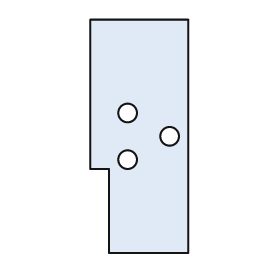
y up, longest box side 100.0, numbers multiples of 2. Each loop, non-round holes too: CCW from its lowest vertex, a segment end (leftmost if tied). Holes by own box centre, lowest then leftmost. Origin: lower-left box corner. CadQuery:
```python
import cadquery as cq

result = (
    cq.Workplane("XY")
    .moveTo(8.0, 0.0)
    .lineTo(42.0, 0.0)
    .lineTo(42.0, 100.0)
    .lineTo(0.0, 100.0)
    .lineTo(0.0, 36.0)
    .lineTo(8.0, 36.0)
    .close()
    .moveTo(16.0, 40.0)
    .circle(4.0)
    .moveTo(34.0, 50.0)
    .circle(4.0)
    .moveTo(16.0, 60.0)
    .circle(4.0)
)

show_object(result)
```